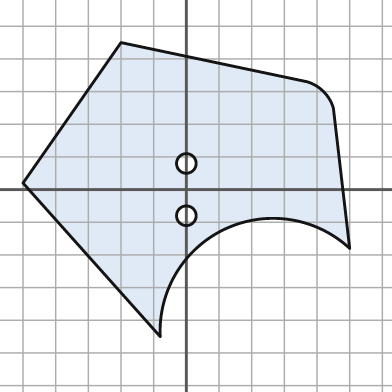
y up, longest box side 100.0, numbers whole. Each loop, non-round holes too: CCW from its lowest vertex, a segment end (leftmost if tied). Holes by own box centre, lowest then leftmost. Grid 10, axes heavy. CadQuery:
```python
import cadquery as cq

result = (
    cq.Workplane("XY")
    .moveTo(-8.0, -45.0)
    .threePointArc((12.0, -12.0), (50.0, -18.0))
    .lineTo(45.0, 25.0)
    .threePointArc((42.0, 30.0), (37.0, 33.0))
    .lineTo(-20.0, 45.0)
    .lineTo(-50.0, 2.0)
    .close()
    .moveTo(0.0, -8.0)
    .circle(3.0)
    .moveTo(0.0, 8.0)
    .circle(3.0)
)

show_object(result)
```